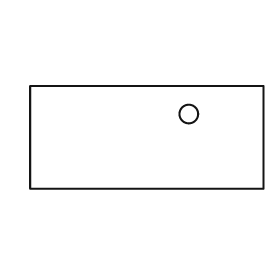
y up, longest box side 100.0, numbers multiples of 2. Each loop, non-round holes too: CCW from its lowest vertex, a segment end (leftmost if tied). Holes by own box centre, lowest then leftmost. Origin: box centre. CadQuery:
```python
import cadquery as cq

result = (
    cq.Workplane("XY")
    .moveTo(-50.0, -22.0)
    .lineTo(50.0, -22.0)
    .lineTo(50.0, 22.0)
    .lineTo(-50.0, 22.0)
    .close()
    .moveTo(18.0, 10.0)
    .circle(4.0)
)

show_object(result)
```